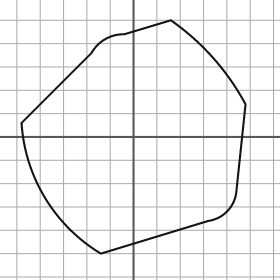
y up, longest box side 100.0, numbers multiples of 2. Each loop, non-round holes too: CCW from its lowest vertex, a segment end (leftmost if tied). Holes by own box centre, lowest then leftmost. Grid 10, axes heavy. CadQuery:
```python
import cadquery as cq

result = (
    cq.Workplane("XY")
    .moveTo(-14.0, -50.0)
    .lineTo(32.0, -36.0)
    .threePointArc((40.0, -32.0), (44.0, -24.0))
    .lineTo(48.0, 14.0)
    .threePointArc((34.0, 34.0), (16.0, 50.0))
    .lineTo(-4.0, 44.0)
    .threePointArc((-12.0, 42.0), (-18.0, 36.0))
    .lineTo(-48.0, 6.0)
    .threePointArc((-38.0, -26.0), (-14.0, -50.0))
    .close()
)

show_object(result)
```